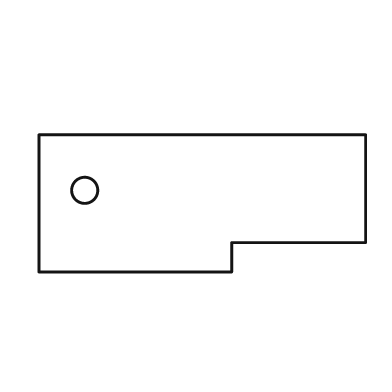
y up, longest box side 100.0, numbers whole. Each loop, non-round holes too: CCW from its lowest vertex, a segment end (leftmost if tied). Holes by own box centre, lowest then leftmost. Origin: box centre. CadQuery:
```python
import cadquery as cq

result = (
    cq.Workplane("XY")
    .moveTo(-50.0, -21.0)
    .lineTo(9.0, -21.0)
    .lineTo(9.0, -12.0)
    .lineTo(50.0, -12.0)
    .lineTo(50.0, 21.0)
    .lineTo(-50.0, 21.0)
    .close()
    .moveTo(-36.0, 4.0)
    .circle(4.0)
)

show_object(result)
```